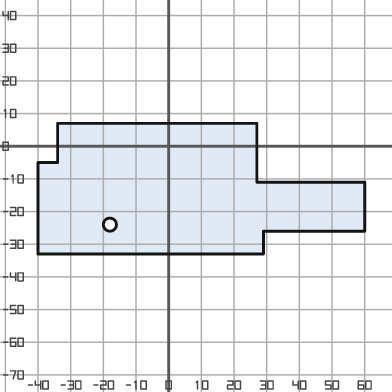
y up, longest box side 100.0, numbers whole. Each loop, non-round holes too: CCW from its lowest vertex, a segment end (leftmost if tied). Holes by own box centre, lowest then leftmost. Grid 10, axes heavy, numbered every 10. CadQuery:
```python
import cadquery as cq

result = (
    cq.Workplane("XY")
    .moveTo(-40.0, -33.0)
    .lineTo(29.0, -33.0)
    .lineTo(29.0, -26.0)
    .lineTo(60.0, -26.0)
    .lineTo(60.0, -11.0)
    .lineTo(27.0, -11.0)
    .lineTo(27.0, 7.0)
    .lineTo(-34.0, 7.0)
    .lineTo(-34.0, -5.0)
    .lineTo(-40.0, -5.0)
    .close()
    .moveTo(-18.0, -24.0)
    .circle(2.0)
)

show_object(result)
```